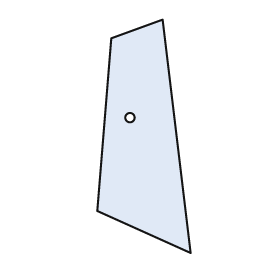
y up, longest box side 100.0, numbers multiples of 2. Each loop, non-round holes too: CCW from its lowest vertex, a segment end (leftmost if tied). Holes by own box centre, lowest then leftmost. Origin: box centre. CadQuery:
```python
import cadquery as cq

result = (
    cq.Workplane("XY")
    .moveTo(20.0, -50.0)
    .lineTo(8.0, 50.0)
    .lineTo(-14.0, 42.0)
    .lineTo(-20.0, -32.0)
    .close()
    .moveTo(-6.0, 8.0)
    .circle(2.0)
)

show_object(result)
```